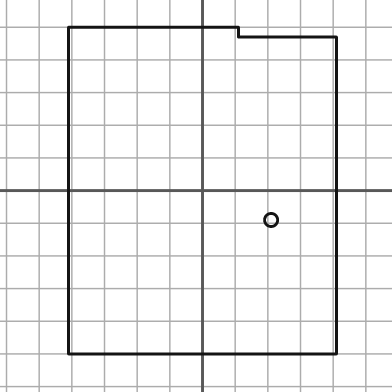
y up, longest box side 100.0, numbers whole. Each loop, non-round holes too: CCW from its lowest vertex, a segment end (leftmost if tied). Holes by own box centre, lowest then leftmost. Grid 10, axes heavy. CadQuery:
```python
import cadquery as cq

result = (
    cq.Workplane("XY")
    .moveTo(-41.0, -50.0)
    .lineTo(41.0, -50.0)
    .lineTo(41.0, 47.0)
    .lineTo(11.0, 47.0)
    .lineTo(11.0, 50.0)
    .lineTo(-41.0, 50.0)
    .close()
    .moveTo(21.0, -9.0)
    .circle(2.0)
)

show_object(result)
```